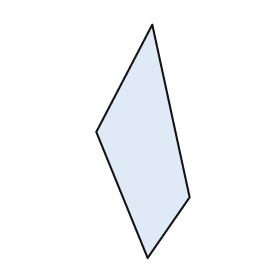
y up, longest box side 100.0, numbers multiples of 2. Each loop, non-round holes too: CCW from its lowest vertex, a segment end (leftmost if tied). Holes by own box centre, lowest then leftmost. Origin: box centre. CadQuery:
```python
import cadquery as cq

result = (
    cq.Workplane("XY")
    .moveTo(2.0, -50.0)
    .lineTo(20.0, -24.0)
    .lineTo(4.0, 50.0)
    .lineTo(-20.0, 4.0)
    .close()
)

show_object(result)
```